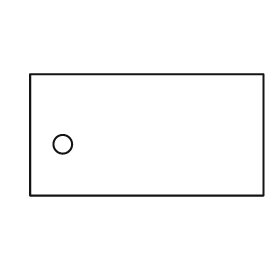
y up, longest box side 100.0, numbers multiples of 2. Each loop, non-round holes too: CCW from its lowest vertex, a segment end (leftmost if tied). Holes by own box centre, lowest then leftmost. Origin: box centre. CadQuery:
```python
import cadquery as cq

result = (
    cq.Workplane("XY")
    .moveTo(-50.0, -26.0)
    .lineTo(50.0, -26.0)
    .lineTo(50.0, 26.0)
    .lineTo(-50.0, 26.0)
    .close()
    .moveTo(-36.0, -4.0)
    .circle(4.0)
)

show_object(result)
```